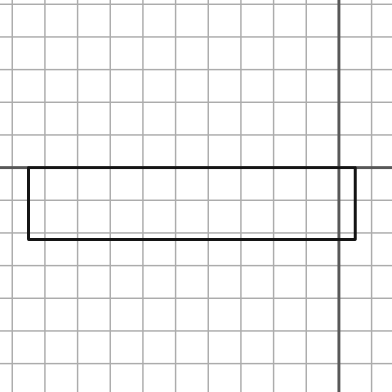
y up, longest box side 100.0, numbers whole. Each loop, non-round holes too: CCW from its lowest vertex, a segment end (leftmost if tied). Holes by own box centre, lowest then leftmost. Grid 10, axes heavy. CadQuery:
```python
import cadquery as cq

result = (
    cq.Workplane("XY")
    .moveTo(-95.0, -22.0)
    .lineTo(5.0, -22.0)
    .lineTo(5.0, 0.0)
    .lineTo(-95.0, 0.0)
    .close()
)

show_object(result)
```